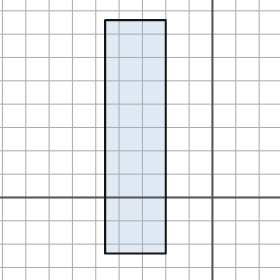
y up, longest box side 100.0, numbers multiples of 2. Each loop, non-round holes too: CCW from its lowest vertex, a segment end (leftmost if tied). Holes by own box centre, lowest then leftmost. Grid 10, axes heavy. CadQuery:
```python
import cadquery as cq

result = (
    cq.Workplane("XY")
    .moveTo(-46.0, -24.0)
    .lineTo(-20.0, -24.0)
    .lineTo(-20.0, 76.0)
    .lineTo(-46.0, 76.0)
    .close()
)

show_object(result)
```